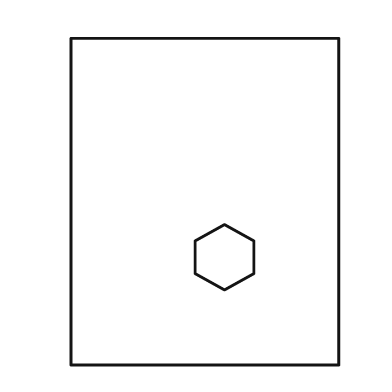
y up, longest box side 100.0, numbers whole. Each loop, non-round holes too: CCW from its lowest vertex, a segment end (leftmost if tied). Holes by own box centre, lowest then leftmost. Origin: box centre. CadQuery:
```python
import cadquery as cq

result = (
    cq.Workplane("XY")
    .moveTo(-41.0, -50.0)
    .lineTo(41.0, -50.0)
    .lineTo(41.0, 50.0)
    .lineTo(-41.0, 50.0)
    .close()
    .moveTo(6.0, -27.0)
    .lineTo(15.0, -22.0)
    .lineTo(15.0, -12.0)
    .lineTo(6.0, -7.0)
    .lineTo(-3.0, -12.0)
    .lineTo(-3.0, -22.0)
    .close()
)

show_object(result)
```